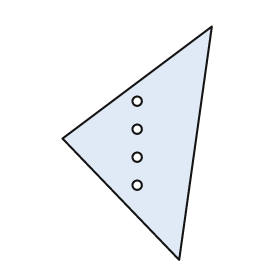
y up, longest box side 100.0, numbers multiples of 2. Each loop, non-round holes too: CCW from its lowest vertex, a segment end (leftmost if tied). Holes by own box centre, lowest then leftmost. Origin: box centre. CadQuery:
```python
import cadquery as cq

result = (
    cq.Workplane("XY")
    .moveTo(18.0, -50.0)
    .lineTo(32.0, 50.0)
    .lineTo(-32.0, 2.0)
    .close()
    .moveTo(0.0, -18.0)
    .circle(2.0)
    .moveTo(0.0, -6.0)
    .circle(2.0)
    .moveTo(0.0, 6.0)
    .circle(2.0)
    .moveTo(0.0, 18.0)
    .circle(2.0)
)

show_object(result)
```